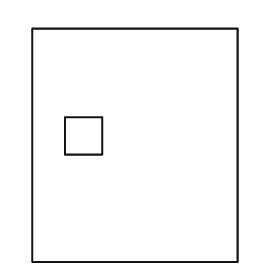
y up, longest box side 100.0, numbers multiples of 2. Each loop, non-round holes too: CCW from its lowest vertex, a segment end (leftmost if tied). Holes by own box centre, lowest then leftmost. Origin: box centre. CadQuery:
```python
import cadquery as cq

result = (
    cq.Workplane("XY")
    .moveTo(-44.0, -50.0)
    .lineTo(44.0, -50.0)
    .lineTo(44.0, 50.0)
    .lineTo(-44.0, 50.0)
    .close()
    .moveTo(-30.0, -4.0)
    .lineTo(-14.0, -4.0)
    .lineTo(-14.0, 12.0)
    .lineTo(-30.0, 12.0)
    .close()
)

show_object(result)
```